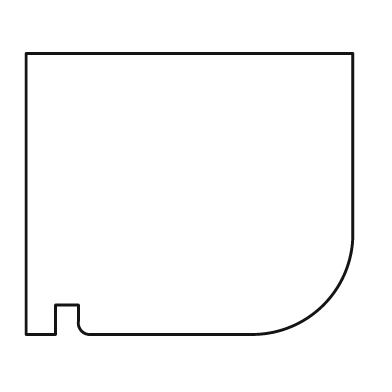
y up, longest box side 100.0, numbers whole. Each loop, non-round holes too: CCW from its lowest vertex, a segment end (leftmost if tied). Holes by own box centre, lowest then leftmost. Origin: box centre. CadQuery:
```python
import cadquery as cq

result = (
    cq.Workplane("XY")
    .moveTo(-50.0, -43.0)
    .lineTo(-41.0, -43.0)
    .lineTo(-41.0, -34.0)
    .lineTo(-34.0, -34.0)
    .lineTo(-34.0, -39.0)
    .threePointArc((-33.0, -42.0), (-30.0, -43.0))
    .lineTo(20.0, -43.0)
    .threePointArc((41.0, -34.0), (50.0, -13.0))
    .lineTo(50.0, 43.0)
    .lineTo(-50.0, 43.0)
    .close()
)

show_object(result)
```